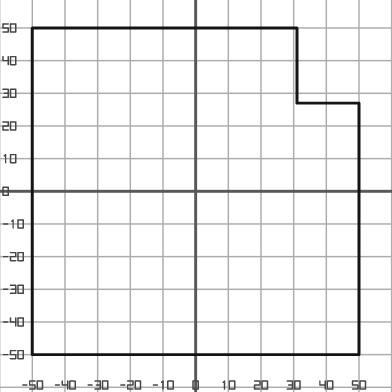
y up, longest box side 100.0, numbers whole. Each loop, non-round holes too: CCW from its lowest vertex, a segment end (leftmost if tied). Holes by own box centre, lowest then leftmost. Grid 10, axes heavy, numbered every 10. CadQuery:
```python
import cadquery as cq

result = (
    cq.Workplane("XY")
    .moveTo(-50.0, -50.0)
    .lineTo(50.0, -50.0)
    .lineTo(50.0, 27.0)
    .lineTo(31.0, 27.0)
    .lineTo(31.0, 50.0)
    .lineTo(-50.0, 50.0)
    .close()
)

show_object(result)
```